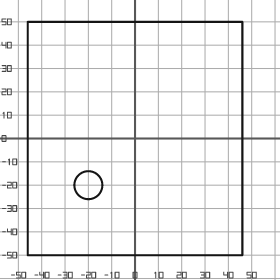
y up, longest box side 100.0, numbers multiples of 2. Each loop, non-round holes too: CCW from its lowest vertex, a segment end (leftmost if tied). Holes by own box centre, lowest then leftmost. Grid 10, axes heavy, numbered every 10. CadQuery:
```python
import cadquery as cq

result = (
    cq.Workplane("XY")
    .moveTo(-46.0, -50.0)
    .lineTo(46.0, -50.0)
    .lineTo(46.0, 50.0)
    .lineTo(-46.0, 50.0)
    .close()
    .moveTo(-20.0, -20.0)
    .circle(6.0)
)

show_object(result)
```